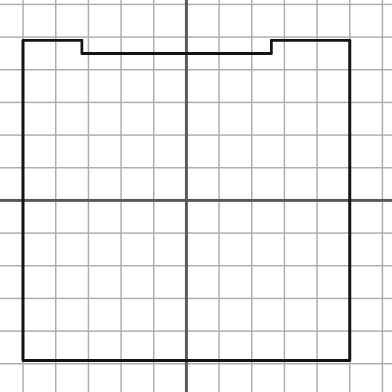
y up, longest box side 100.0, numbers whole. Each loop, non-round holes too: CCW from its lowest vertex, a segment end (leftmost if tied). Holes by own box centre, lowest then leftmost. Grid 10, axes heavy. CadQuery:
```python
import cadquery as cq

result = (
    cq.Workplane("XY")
    .moveTo(-50.0, -49.0)
    .lineTo(50.0, -49.0)
    .lineTo(50.0, 49.0)
    .lineTo(26.0, 49.0)
    .lineTo(26.0, 45.0)
    .lineTo(-32.0, 45.0)
    .lineTo(-32.0, 49.0)
    .lineTo(-50.0, 49.0)
    .close()
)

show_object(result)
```